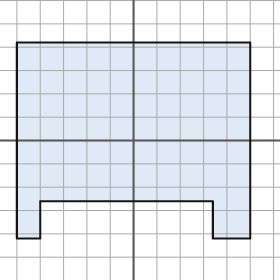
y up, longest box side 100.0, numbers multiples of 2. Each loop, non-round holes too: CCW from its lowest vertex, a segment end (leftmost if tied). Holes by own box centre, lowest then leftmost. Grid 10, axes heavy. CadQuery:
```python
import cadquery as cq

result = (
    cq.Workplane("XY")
    .moveTo(-50.0, -42.0)
    .lineTo(-40.0, -42.0)
    .lineTo(-40.0, -26.0)
    .lineTo(34.0, -26.0)
    .lineTo(34.0, -42.0)
    .lineTo(50.0, -42.0)
    .lineTo(50.0, 42.0)
    .lineTo(-50.0, 42.0)
    .close()
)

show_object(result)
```